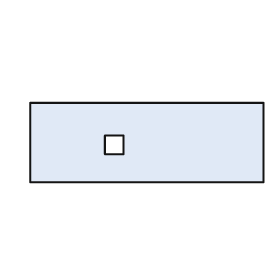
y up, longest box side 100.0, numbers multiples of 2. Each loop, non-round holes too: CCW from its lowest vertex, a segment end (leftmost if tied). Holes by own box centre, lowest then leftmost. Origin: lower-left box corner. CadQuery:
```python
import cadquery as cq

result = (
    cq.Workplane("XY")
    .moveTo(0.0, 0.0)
    .lineTo(100.0, 0.0)
    .lineTo(100.0, 34.0)
    .lineTo(0.0, 34.0)
    .close()
    .moveTo(32.0, 12.0)
    .lineTo(40.0, 12.0)
    .lineTo(40.0, 20.0)
    .lineTo(32.0, 20.0)
    .close()
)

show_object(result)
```